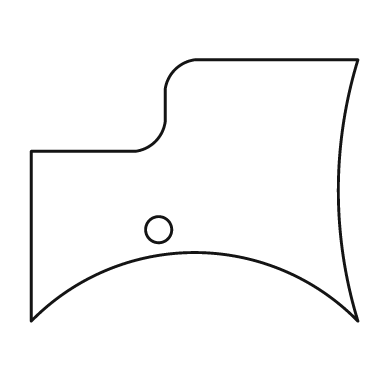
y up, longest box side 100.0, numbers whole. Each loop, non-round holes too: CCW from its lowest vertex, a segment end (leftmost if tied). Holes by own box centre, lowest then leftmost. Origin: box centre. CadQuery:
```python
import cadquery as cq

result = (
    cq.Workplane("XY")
    .moveTo(-50.0, -40.0)
    .threePointArc((0.0, -19.0), (50.0, -40.0))
    .threePointArc((44.0, 0.0), (50.0, 40.0))
    .lineTo(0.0, 40.0)
    .threePointArc((-6.0, 37.0), (-9.0, 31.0))
    .lineTo(-9.0, 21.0)
    .threePointArc((-12.0, 15.0), (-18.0, 12.0))
    .lineTo(-50.0, 12.0)
    .close()
    .moveTo(-11.0, -12.0)
    .circle(4.0)
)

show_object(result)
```